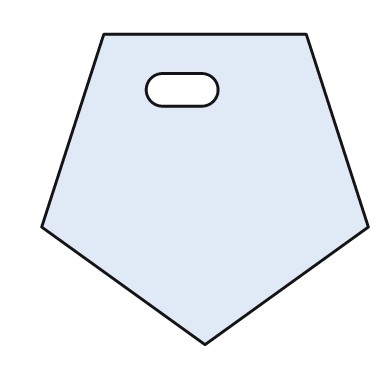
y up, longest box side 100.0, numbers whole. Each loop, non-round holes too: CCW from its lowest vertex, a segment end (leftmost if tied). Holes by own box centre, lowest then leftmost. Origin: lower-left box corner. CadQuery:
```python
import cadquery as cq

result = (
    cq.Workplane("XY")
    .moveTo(50.0, 0.0)
    .lineTo(100.0, 36.0)
    .lineTo(81.0, 95.0)
    .lineTo(19.0, 95.0)
    .lineTo(0.0, 36.0)
    .close()
    .moveTo(37.0, 73.0)
    .lineTo(49.0, 73.0)
    .threePointArc((54.0, 78.0), (49.0, 83.0))
    .lineTo(37.0, 83.0)
    .threePointArc((32.0, 78.0), (37.0, 73.0))
    .close()
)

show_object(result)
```